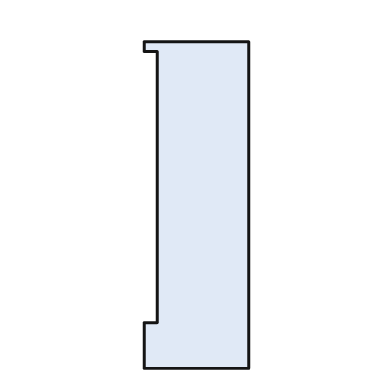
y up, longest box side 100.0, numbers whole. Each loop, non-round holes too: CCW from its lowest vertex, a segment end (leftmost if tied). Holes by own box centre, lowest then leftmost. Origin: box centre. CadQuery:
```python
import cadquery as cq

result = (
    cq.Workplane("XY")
    .moveTo(-16.0, -50.0)
    .lineTo(16.0, -50.0)
    .lineTo(16.0, 50.0)
    .lineTo(-16.0, 50.0)
    .lineTo(-16.0, 47.0)
    .lineTo(-12.0, 47.0)
    .lineTo(-12.0, -36.0)
    .lineTo(-16.0, -36.0)
    .close()
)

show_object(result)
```